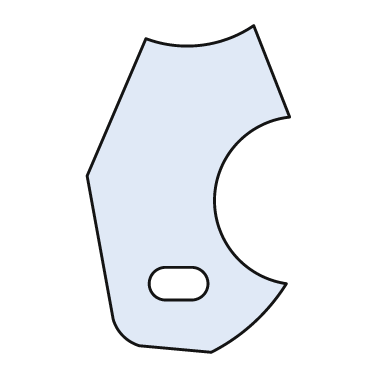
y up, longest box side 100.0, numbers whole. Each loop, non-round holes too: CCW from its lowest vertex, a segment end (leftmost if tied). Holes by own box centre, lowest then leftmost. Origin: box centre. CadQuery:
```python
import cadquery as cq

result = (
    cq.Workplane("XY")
    .moveTo(7.0, -50.0)
    .threePointArc((20.0, -41.0), (30.0, -29.0))
    .threePointArc((8.0, -3.0), (31.0, 22.0))
    .lineTo(20.0, 50.0)
    .threePointArc((4.0, 44.0), (-13.0, 46.0))
    .lineTo(-31.0, 4.0)
    .lineTo(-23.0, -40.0)
    .threePointArc((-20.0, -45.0), (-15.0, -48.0))
    .close()
    .moveTo(-7.0, -34.0)
    .lineTo(1.0, -34.0)
    .threePointArc((6.0, -29.0), (1.0, -24.0))
    .lineTo(-7.0, -24.0)
    .threePointArc((-12.0, -29.0), (-7.0, -34.0))
    .close()
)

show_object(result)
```